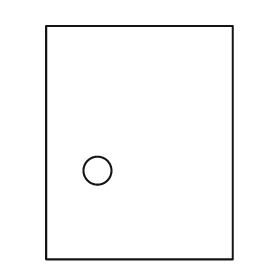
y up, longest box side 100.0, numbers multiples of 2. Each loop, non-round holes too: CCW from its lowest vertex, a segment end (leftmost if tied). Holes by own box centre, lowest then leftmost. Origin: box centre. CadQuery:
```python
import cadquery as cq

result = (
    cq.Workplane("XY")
    .moveTo(-40.0, -50.0)
    .lineTo(40.0, -50.0)
    .lineTo(40.0, 50.0)
    .lineTo(-40.0, 50.0)
    .close()
    .moveTo(-18.0, -12.0)
    .circle(6.0)
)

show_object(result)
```